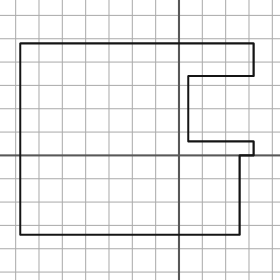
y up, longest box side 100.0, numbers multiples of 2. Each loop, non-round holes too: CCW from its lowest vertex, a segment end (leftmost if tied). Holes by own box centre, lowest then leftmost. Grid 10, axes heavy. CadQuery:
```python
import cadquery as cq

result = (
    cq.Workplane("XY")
    .moveTo(-68.0, -34.0)
    .lineTo(26.0, -34.0)
    .lineTo(26.0, 0.0)
    .lineTo(32.0, 0.0)
    .lineTo(32.0, 6.0)
    .lineTo(4.0, 6.0)
    .lineTo(4.0, 34.0)
    .lineTo(32.0, 34.0)
    .lineTo(32.0, 48.0)
    .lineTo(-68.0, 48.0)
    .close()
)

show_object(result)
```